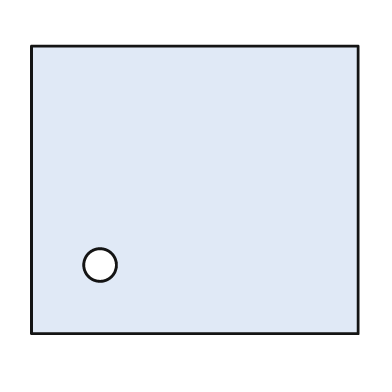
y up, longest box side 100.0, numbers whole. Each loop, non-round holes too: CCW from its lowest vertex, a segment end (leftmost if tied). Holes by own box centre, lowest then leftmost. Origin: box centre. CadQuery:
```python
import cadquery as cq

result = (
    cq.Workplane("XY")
    .moveTo(-50.0, -44.0)
    .lineTo(50.0, -44.0)
    .lineTo(50.0, 44.0)
    .lineTo(-50.0, 44.0)
    .close()
    .moveTo(-29.0, -23.0)
    .circle(5.0)
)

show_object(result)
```